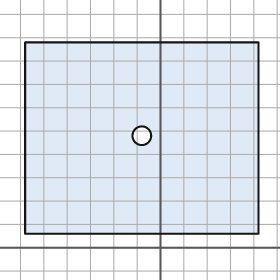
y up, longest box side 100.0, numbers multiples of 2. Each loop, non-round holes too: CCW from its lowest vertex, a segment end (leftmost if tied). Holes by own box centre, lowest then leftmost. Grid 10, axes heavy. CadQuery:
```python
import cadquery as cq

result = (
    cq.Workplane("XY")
    .moveTo(-58.0, 6.0)
    .lineTo(42.0, 6.0)
    .lineTo(42.0, 88.0)
    .lineTo(-58.0, 88.0)
    .close()
    .moveTo(-8.0, 48.0)
    .circle(4.0)
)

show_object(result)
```